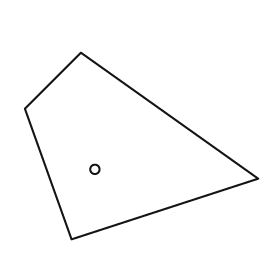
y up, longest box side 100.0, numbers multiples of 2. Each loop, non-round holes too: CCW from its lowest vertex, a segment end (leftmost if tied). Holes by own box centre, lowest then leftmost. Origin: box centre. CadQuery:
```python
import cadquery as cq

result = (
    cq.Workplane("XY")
    .moveTo(-30.0, -40.0)
    .lineTo(50.0, -14.0)
    .lineTo(-26.0, 40.0)
    .lineTo(-50.0, 16.0)
    .close()
    .moveTo(-20.0, -10.0)
    .circle(2.0)
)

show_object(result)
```